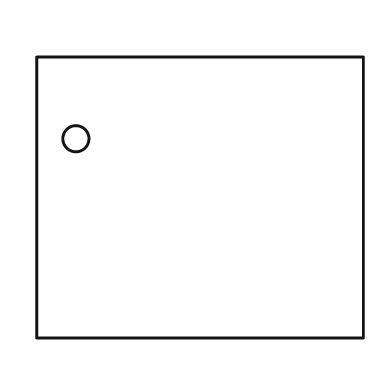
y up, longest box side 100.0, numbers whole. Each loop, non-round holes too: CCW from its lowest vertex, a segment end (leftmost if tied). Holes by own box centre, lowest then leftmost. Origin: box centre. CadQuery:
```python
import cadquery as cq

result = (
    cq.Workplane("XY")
    .moveTo(-50.0, -43.0)
    .lineTo(50.0, -43.0)
    .lineTo(50.0, 43.0)
    .lineTo(-50.0, 43.0)
    .close()
    .moveTo(-38.0, 18.0)
    .circle(4.0)
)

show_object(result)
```